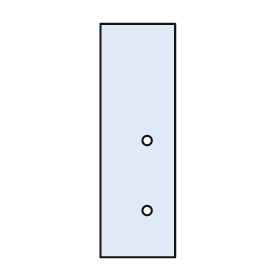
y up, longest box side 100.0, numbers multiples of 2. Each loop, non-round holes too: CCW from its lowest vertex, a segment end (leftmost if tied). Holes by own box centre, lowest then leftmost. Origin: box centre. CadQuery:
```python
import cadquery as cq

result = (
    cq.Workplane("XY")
    .moveTo(-16.0, -50.0)
    .lineTo(16.0, -50.0)
    .lineTo(16.0, 50.0)
    .lineTo(-16.0, 50.0)
    .close()
    .moveTo(4.0, -30.0)
    .circle(2.0)
    .moveTo(4.0, 0.0)
    .circle(2.0)
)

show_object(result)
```